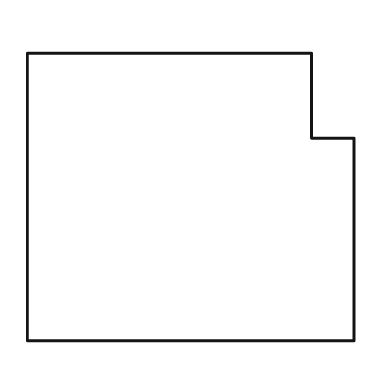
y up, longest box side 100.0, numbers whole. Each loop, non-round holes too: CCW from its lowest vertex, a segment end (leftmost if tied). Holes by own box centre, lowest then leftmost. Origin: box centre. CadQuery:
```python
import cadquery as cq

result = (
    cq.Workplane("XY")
    .moveTo(-50.0, -44.0)
    .lineTo(50.0, -44.0)
    .lineTo(50.0, 18.0)
    .lineTo(37.0, 18.0)
    .lineTo(37.0, 44.0)
    .lineTo(-50.0, 44.0)
    .close()
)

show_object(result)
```